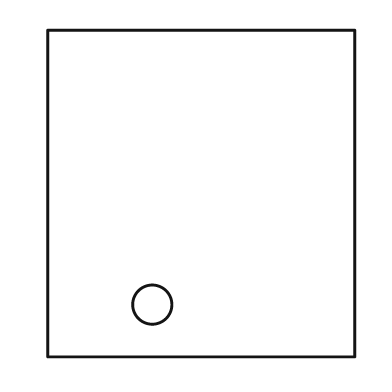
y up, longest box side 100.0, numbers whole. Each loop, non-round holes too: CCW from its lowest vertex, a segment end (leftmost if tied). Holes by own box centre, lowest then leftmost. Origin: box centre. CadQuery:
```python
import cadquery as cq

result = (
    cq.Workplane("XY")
    .moveTo(-47.0, -50.0)
    .lineTo(47.0, -50.0)
    .lineTo(47.0, 50.0)
    .lineTo(-47.0, 50.0)
    .close()
    .moveTo(-15.0, -34.0)
    .circle(6.0)
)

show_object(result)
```